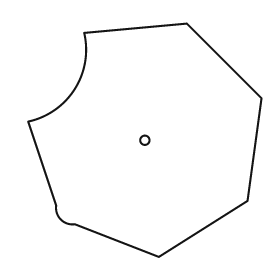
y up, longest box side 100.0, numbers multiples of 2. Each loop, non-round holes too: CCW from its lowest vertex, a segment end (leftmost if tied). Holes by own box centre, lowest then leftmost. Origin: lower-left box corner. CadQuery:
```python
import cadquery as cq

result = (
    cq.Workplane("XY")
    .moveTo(56.0, 0.0)
    .lineTo(94.0, 24.0)
    .lineTo(100.0, 68.0)
    .lineTo(68.0, 100.0)
    .lineTo(24.0, 96.0)
    .threePointArc((20.0, 72.0), (0.0, 58.0))
    .lineTo(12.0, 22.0)
    .threePointArc((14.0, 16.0), (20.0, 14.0))
    .close()
    .moveTo(50.0, 50.0)
    .circle(2.0)
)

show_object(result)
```